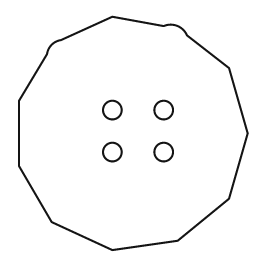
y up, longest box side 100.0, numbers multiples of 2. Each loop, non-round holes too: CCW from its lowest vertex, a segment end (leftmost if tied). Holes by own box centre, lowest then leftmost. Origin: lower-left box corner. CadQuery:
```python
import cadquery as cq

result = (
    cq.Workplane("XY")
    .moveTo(40.0, 0.0)
    .lineTo(68.0, 4.0)
    .lineTo(90.0, 22.0)
    .lineTo(98.0, 50.0)
    .lineTo(90.0, 78.0)
    .lineTo(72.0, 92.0)
    .threePointArc((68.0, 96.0), (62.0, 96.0))
    .lineTo(40.0, 100.0)
    .lineTo(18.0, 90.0)
    .threePointArc((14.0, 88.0), (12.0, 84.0))
    .lineTo(0.0, 64.0)
    .lineTo(0.0, 36.0)
    .lineTo(14.0, 12.0)
    .close()
    .moveTo(40.0, 42.0)
    .circle(4.0)
    .moveTo(62.0, 42.0)
    .circle(4.0)
    .moveTo(40.0, 60.0)
    .circle(4.0)
    .moveTo(62.0, 60.0)
    .circle(4.0)
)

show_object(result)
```